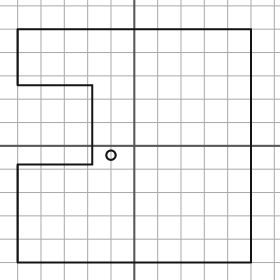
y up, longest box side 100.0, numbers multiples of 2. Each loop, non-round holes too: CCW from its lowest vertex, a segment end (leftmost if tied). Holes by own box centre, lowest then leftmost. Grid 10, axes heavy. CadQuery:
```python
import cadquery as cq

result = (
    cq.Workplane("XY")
    .moveTo(-50.0, -50.0)
    .lineTo(50.0, -50.0)
    .lineTo(50.0, 50.0)
    .lineTo(-50.0, 50.0)
    .lineTo(-50.0, 26.0)
    .lineTo(-18.0, 26.0)
    .lineTo(-18.0, -8.0)
    .lineTo(-50.0, -8.0)
    .close()
    .moveTo(-10.0, -4.0)
    .circle(2.0)
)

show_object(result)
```